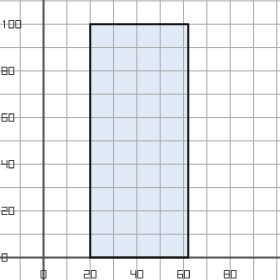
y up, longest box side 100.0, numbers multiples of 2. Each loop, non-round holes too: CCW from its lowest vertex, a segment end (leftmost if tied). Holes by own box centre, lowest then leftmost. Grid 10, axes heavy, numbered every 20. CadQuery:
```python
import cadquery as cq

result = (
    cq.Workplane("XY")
    .moveTo(20.0, 0.0)
    .lineTo(62.0, 0.0)
    .lineTo(62.0, 100.0)
    .lineTo(20.0, 100.0)
    .close()
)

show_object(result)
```